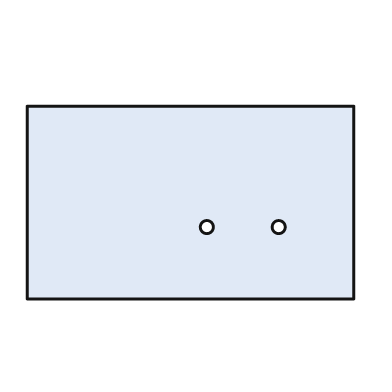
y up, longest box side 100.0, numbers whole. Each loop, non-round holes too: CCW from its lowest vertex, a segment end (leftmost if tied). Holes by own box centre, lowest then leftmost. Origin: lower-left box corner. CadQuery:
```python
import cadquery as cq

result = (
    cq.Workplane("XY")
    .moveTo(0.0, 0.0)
    .lineTo(100.0, 0.0)
    .lineTo(100.0, 59.0)
    .lineTo(0.0, 59.0)
    .close()
    .moveTo(55.0, 22.0)
    .circle(2.0)
    .moveTo(77.0, 22.0)
    .circle(2.0)
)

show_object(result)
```